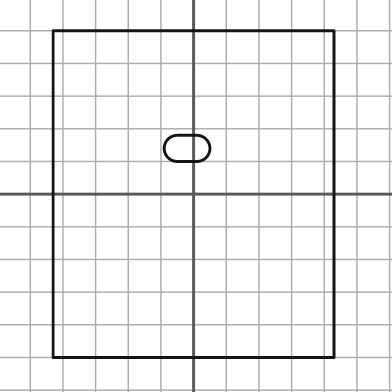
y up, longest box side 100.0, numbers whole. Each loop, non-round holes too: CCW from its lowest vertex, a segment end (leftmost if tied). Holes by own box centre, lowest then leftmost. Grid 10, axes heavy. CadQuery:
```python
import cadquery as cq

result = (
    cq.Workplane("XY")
    .moveTo(-43.0, -50.0)
    .lineTo(43.0, -50.0)
    .lineTo(43.0, 50.0)
    .lineTo(-43.0, 50.0)
    .close()
    .moveTo(-5.0, 10.0)
    .lineTo(1.0, 10.0)
    .threePointArc((5.0, 14.0), (1.0, 18.0))
    .lineTo(-5.0, 18.0)
    .threePointArc((-9.0, 14.0), (-5.0, 10.0))
    .close()
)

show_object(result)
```